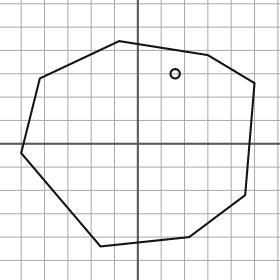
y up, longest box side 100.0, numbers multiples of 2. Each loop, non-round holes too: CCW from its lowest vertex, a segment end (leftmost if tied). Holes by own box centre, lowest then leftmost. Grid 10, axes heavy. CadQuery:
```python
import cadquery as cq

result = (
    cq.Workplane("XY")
    .moveTo(-16.0, -44.0)
    .lineTo(22.0, -40.0)
    .lineTo(46.0, -22.0)
    .lineTo(50.0, 26.0)
    .lineTo(30.0, 38.0)
    .lineTo(-8.0, 44.0)
    .lineTo(-42.0, 28.0)
    .lineTo(-50.0, -4.0)
    .close()
    .moveTo(16.0, 30.0)
    .circle(2.0)
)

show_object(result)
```